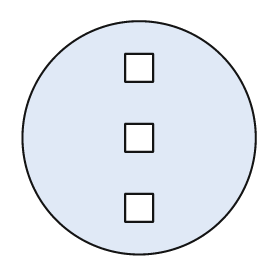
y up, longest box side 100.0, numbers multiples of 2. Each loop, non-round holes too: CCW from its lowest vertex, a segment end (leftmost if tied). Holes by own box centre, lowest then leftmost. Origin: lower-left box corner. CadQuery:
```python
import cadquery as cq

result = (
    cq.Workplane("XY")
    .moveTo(50.0, 50.0)
    .circle(50.0)
    .moveTo(44.0, 14.0)
    .lineTo(56.0, 14.0)
    .lineTo(56.0, 26.0)
    .lineTo(44.0, 26.0)
    .close()
    .moveTo(44.0, 44.0)
    .lineTo(56.0, 44.0)
    .lineTo(56.0, 56.0)
    .lineTo(44.0, 56.0)
    .close()
    .moveTo(44.0, 74.0)
    .lineTo(56.0, 74.0)
    .lineTo(56.0, 86.0)
    .lineTo(44.0, 86.0)
    .close()
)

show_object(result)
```